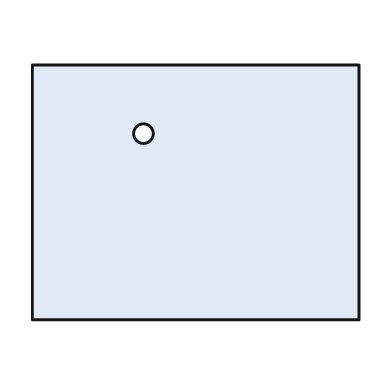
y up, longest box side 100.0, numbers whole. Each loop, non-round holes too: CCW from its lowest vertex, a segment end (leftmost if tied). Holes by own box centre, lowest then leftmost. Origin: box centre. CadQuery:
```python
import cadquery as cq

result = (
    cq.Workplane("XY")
    .moveTo(-50.0, -39.0)
    .lineTo(50.0, -39.0)
    .lineTo(50.0, 39.0)
    .lineTo(-50.0, 39.0)
    .close()
    .moveTo(-16.0, 18.0)
    .circle(3.0)
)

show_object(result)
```